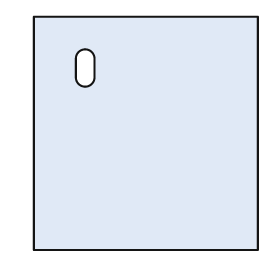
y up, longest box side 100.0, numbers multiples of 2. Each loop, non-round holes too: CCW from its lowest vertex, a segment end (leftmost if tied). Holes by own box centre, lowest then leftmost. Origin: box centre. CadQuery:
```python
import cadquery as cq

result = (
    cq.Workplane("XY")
    .moveTo(-48.0, -50.0)
    .lineTo(48.0, -50.0)
    .lineTo(48.0, 50.0)
    .lineTo(-48.0, 50.0)
    .close()
    .moveTo(-30.0, 24.0)
    .threePointArc((-26.0, 20.0), (-22.0, 24.0))
    .lineTo(-22.0, 32.0)
    .threePointArc((-26.0, 36.0), (-30.0, 32.0))
    .close()
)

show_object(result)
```